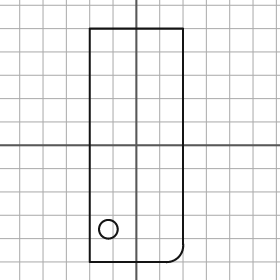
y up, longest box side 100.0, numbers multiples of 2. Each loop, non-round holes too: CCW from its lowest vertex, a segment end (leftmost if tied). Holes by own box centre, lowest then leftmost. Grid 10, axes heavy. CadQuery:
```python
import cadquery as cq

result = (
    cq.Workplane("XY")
    .moveTo(-20.0, -50.0)
    .lineTo(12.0, -50.0)
    .threePointArc((18.0, -48.0), (20.0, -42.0))
    .lineTo(20.0, 50.0)
    .lineTo(-20.0, 50.0)
    .close()
    .moveTo(-12.0, -36.0)
    .circle(4.0)
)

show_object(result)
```